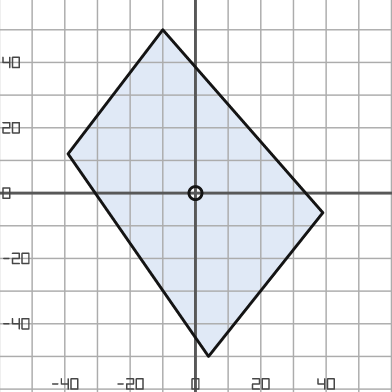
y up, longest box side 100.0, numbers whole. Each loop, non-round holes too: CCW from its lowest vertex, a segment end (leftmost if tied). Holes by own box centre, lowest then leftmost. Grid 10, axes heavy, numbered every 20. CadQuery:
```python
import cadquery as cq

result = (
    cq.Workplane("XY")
    .moveTo(4.0, -50.0)
    .lineTo(39.0, -6.0)
    .lineTo(-10.0, 50.0)
    .lineTo(-39.0, 12.0)
    .close()
    .moveTo(0.0, 0.0)
    .circle(2.0)
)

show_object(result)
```